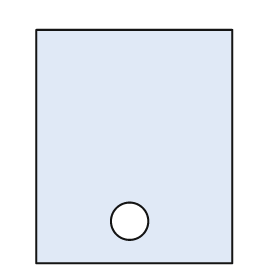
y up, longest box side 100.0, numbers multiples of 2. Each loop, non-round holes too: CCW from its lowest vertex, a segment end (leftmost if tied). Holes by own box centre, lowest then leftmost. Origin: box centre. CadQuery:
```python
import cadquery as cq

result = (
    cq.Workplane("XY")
    .moveTo(-42.0, -50.0)
    .lineTo(42.0, -50.0)
    .lineTo(42.0, 50.0)
    .lineTo(-42.0, 50.0)
    .close()
    .moveTo(-2.0, -32.0)
    .circle(8.0)
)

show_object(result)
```